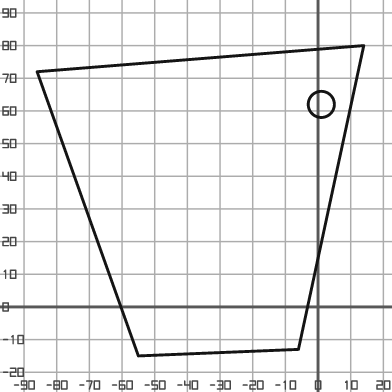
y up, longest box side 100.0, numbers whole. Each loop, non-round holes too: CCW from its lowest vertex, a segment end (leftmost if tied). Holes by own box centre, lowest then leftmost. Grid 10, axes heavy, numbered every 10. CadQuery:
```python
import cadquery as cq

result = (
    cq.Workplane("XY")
    .moveTo(-55.0, -15.0)
    .lineTo(-6.0, -13.0)
    .lineTo(14.0, 80.0)
    .lineTo(-86.0, 72.0)
    .close()
    .moveTo(1.0, 62.0)
    .circle(4.0)
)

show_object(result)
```